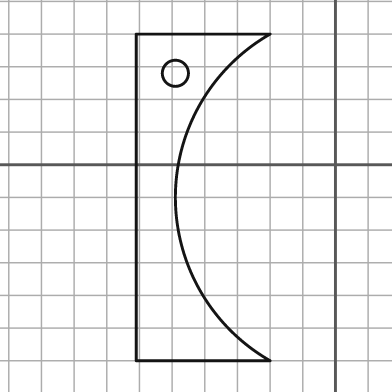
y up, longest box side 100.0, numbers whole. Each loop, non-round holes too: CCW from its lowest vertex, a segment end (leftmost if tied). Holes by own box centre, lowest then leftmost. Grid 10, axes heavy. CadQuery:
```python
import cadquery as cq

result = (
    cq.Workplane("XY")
    .moveTo(-61.0, -60.0)
    .lineTo(-20.0, -60.0)
    .threePointArc((-49.0, -10.0), (-20.0, 40.0))
    .lineTo(-61.0, 40.0)
    .close()
    .moveTo(-49.0, 28.0)
    .circle(4.0)
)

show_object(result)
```